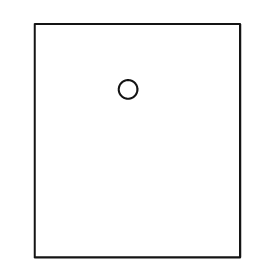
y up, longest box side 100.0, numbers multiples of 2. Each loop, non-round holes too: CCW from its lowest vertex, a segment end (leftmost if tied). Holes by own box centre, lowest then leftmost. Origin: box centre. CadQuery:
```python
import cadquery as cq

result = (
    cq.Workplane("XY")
    .moveTo(-44.0, -50.0)
    .lineTo(44.0, -50.0)
    .lineTo(44.0, 50.0)
    .lineTo(-44.0, 50.0)
    .close()
    .moveTo(-4.0, 22.0)
    .circle(4.0)
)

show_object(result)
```